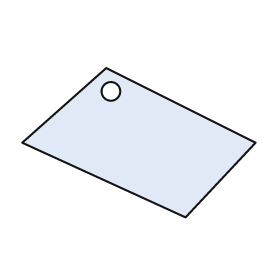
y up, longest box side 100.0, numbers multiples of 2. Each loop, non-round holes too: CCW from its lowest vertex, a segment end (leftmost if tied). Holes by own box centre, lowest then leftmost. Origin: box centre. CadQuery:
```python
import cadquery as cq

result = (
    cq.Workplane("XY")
    .moveTo(20.0, -32.0)
    .lineTo(50.0, 0.0)
    .lineTo(-14.0, 32.0)
    .lineTo(-50.0, 0.0)
    .close()
    .moveTo(-12.0, 22.0)
    .circle(4.0)
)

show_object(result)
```